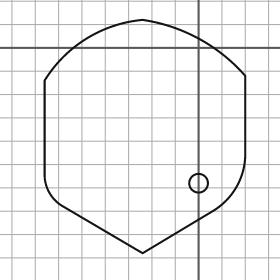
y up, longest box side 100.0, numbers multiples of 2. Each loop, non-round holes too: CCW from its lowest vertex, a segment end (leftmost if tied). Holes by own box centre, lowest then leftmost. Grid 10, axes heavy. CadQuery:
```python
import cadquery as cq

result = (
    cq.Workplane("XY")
    .moveTo(-24.0, -88.0)
    .lineTo(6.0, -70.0)
    .threePointArc((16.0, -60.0), (20.0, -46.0))
    .lineTo(20.0, -12.0)
    .threePointArc((0.0, 4.0), (-24.0, 12.0))
    .threePointArc((-48.0, 4.0), (-66.0, -14.0))
    .lineTo(-66.0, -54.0)
    .threePointArc((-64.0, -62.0), (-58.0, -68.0))
    .close()
    .moveTo(0.0, -58.0)
    .circle(4.0)
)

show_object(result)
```